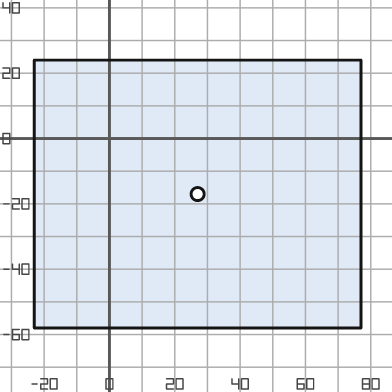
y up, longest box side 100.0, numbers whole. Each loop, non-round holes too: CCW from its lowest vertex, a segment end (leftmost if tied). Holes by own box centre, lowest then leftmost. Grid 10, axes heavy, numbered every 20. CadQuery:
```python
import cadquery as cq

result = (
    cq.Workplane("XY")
    .moveTo(-23.0, -58.0)
    .lineTo(77.0, -58.0)
    .lineTo(77.0, 24.0)
    .lineTo(-23.0, 24.0)
    .close()
    .moveTo(27.0, -17.0)
    .circle(2.0)
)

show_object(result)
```